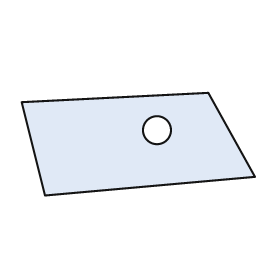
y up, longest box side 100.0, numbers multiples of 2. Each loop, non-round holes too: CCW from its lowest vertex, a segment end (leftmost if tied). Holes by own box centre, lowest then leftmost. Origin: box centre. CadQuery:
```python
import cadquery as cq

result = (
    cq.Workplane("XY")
    .moveTo(-40.0, -22.0)
    .lineTo(50.0, -14.0)
    .lineTo(30.0, 22.0)
    .lineTo(-50.0, 18.0)
    .close()
    .moveTo(8.0, 6.0)
    .circle(6.0)
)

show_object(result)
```